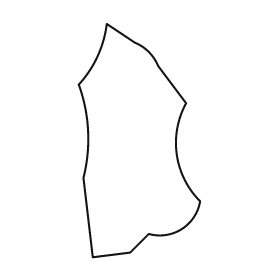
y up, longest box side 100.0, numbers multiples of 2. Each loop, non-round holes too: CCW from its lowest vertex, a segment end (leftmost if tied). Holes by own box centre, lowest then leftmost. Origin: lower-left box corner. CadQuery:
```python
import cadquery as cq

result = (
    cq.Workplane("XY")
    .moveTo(6.0, 0.0)
    .lineTo(22.0, 2.0)
    .lineTo(30.0, 10.0)
    .threePointArc((44.0, 12.0), (52.0, 24.0))
    .threePointArc((42.0, 44.0), (46.0, 66.0))
    .lineTo(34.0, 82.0)
    .threePointArc((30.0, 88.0), (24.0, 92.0))
    .lineTo(12.0, 100.0)
    .threePointArc((8.0, 86.0), (0.0, 74.0))
    .threePointArc((4.0, 54.0), (2.0, 34.0))
    .close()
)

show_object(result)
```